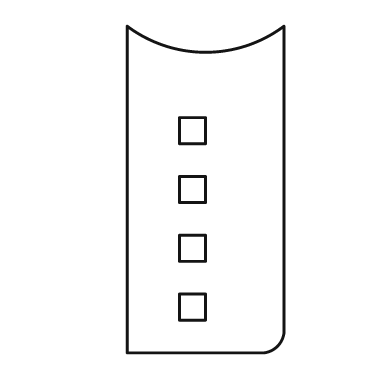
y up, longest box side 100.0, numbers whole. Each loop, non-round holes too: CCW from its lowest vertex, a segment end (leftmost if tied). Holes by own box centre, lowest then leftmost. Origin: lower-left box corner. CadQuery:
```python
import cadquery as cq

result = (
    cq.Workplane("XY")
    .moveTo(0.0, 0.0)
    .lineTo(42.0, 0.0)
    .threePointArc((46.0, 2.0), (48.0, 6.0))
    .lineTo(48.0, 100.0)
    .threePointArc((24.0, 92.0), (0.0, 100.0))
    .close()
    .moveTo(16.0, 10.0)
    .lineTo(24.0, 10.0)
    .lineTo(24.0, 18.0)
    .lineTo(16.0, 18.0)
    .close()
    .moveTo(16.0, 28.0)
    .lineTo(24.0, 28.0)
    .lineTo(24.0, 36.0)
    .lineTo(16.0, 36.0)
    .close()
    .moveTo(16.0, 46.0)
    .lineTo(24.0, 46.0)
    .lineTo(24.0, 54.0)
    .lineTo(16.0, 54.0)
    .close()
    .moveTo(16.0, 64.0)
    .lineTo(24.0, 64.0)
    .lineTo(24.0, 72.0)
    .lineTo(16.0, 72.0)
    .close()
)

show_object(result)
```